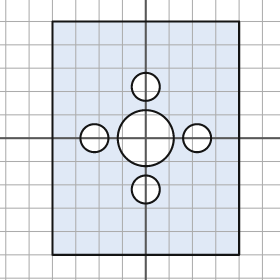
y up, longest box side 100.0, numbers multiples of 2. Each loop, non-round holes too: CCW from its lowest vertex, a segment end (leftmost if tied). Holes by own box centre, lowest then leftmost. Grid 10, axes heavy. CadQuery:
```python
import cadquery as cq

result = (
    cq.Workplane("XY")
    .moveTo(-40.0, -50.0)
    .lineTo(40.0, -50.0)
    .lineTo(40.0, 50.0)
    .lineTo(-40.0, 50.0)
    .close()
    .moveTo(0.0, -22.0)
    .circle(6.0)
    .moveTo(-22.0, 0.0)
    .circle(6.0)
    .moveTo(0.0, 0.0)
    .circle(12.0)
    .moveTo(22.0, 0.0)
    .circle(6.0)
    .moveTo(0.0, 22.0)
    .circle(6.0)
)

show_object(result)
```